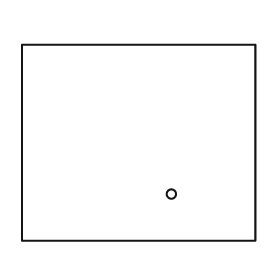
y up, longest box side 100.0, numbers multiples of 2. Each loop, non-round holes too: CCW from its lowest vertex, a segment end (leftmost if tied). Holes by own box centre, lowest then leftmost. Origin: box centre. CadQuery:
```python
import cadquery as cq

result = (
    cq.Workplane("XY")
    .moveTo(-50.0, -42.0)
    .lineTo(50.0, -42.0)
    .lineTo(50.0, 42.0)
    .lineTo(-50.0, 42.0)
    .close()
    .moveTo(14.0, -22.0)
    .circle(2.0)
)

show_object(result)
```